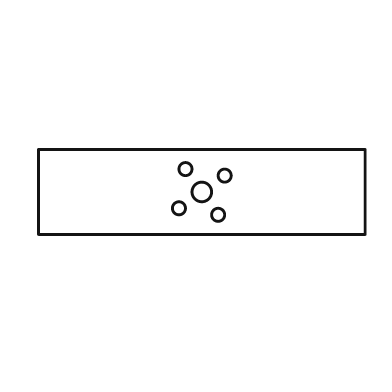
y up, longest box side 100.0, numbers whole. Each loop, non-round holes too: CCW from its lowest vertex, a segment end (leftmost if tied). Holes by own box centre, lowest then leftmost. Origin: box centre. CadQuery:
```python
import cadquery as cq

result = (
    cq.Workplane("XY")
    .moveTo(-50.0, -13.0)
    .lineTo(50.0, -13.0)
    .lineTo(50.0, 13.0)
    .lineTo(-50.0, 13.0)
    .close()
    .moveTo(5.0, -7.0)
    .circle(2.0)
    .moveTo(-7.0, -5.0)
    .circle(2.0)
    .moveTo(0.0, 0.0)
    .circle(3.0)
    .moveTo(7.0, 5.0)
    .circle(2.0)
    .moveTo(-5.0, 7.0)
    .circle(2.0)
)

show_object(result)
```